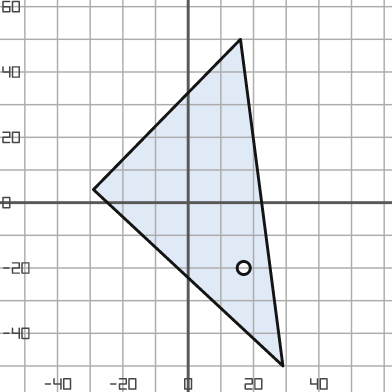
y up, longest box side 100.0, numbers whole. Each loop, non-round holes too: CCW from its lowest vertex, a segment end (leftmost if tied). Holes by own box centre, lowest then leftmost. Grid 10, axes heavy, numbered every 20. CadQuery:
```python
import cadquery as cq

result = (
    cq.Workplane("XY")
    .moveTo(29.0, -50.0)
    .lineTo(16.0, 50.0)
    .lineTo(-29.0, 4.0)
    .close()
    .moveTo(17.0, -20.0)
    .circle(2.0)
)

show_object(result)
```